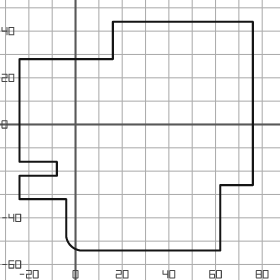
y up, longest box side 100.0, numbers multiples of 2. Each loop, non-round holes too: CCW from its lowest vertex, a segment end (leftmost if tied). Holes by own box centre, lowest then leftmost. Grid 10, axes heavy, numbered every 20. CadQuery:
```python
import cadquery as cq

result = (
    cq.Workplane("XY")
    .moveTo(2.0, -54.0)
    .lineTo(62.0, -54.0)
    .lineTo(62.0, -26.0)
    .lineTo(76.0, -26.0)
    .lineTo(76.0, 44.0)
    .lineTo(16.0, 44.0)
    .lineTo(16.0, 28.0)
    .lineTo(-24.0, 28.0)
    .lineTo(-24.0, -16.0)
    .lineTo(-8.0, -16.0)
    .lineTo(-8.0, -22.0)
    .lineTo(-24.0, -22.0)
    .lineTo(-24.0, -32.0)
    .lineTo(-4.0, -32.0)
    .lineTo(-4.0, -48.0)
    .threePointArc((-2.0, -52.0), (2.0, -54.0))
    .close()
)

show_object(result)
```